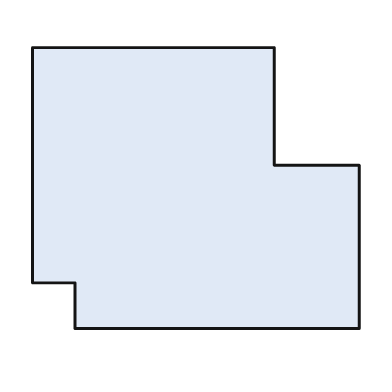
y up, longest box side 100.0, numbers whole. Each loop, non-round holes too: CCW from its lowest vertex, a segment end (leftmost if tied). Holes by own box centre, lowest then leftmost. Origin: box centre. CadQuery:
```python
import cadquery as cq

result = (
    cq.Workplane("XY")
    .moveTo(-37.0, -43.0)
    .lineTo(50.0, -43.0)
    .lineTo(50.0, 7.0)
    .lineTo(24.0, 7.0)
    .lineTo(24.0, 43.0)
    .lineTo(-50.0, 43.0)
    .lineTo(-50.0, -29.0)
    .lineTo(-37.0, -29.0)
    .close()
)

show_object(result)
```